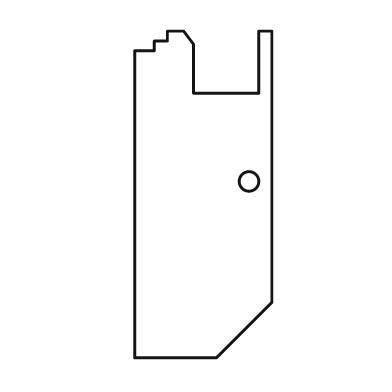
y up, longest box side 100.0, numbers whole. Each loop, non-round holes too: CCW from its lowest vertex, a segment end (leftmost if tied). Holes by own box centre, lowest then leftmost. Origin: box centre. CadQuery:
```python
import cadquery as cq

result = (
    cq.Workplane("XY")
    .moveTo(-21.0, -50.0)
    .lineTo(4.0, -50.0)
    .lineTo(21.0, -33.0)
    .lineTo(21.0, 50.0)
    .lineTo(17.0, 50.0)
    .lineTo(17.0, 31.0)
    .lineTo(-3.0, 31.0)
    .lineTo(-3.0, 46.0)
    .lineTo(-6.0, 50.0)
    .lineTo(-11.0, 50.0)
    .lineTo(-11.0, 47.0)
    .lineTo(-15.0, 47.0)
    .lineTo(-15.0, 44.0)
    .lineTo(-21.0, 44.0)
    .close()
    .moveTo(14.0, 4.0)
    .circle(3.0)
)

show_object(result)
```